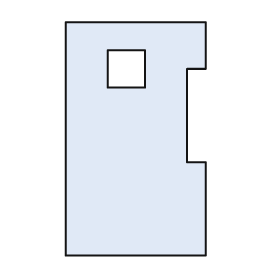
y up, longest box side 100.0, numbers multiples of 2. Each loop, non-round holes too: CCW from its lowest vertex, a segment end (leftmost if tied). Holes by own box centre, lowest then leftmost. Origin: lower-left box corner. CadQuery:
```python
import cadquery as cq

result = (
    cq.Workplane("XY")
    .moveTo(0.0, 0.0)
    .lineTo(60.0, 0.0)
    .lineTo(60.0, 40.0)
    .lineTo(52.0, 40.0)
    .lineTo(52.0, 80.0)
    .lineTo(60.0, 80.0)
    .lineTo(60.0, 100.0)
    .lineTo(0.0, 100.0)
    .close()
    .moveTo(18.0, 72.0)
    .lineTo(34.0, 72.0)
    .lineTo(34.0, 88.0)
    .lineTo(18.0, 88.0)
    .close()
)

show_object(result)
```